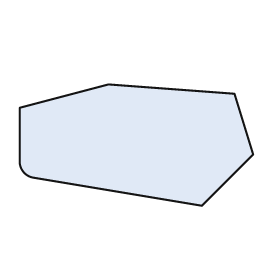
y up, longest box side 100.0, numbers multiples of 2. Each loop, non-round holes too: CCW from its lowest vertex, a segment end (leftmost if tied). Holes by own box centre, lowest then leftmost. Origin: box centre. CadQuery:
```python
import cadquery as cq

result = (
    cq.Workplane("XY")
    .moveTo(28.0, -26.0)
    .lineTo(50.0, -4.0)
    .lineTo(42.0, 22.0)
    .lineTo(-12.0, 26.0)
    .lineTo(-50.0, 16.0)
    .lineTo(-50.0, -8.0)
    .threePointArc((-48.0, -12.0), (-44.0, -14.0))
    .close()
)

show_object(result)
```